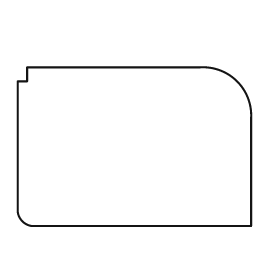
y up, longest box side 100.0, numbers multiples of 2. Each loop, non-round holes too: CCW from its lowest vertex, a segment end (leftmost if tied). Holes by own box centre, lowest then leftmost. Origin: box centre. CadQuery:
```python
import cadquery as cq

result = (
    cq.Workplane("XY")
    .moveTo(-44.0, -34.0)
    .lineTo(50.0, -34.0)
    .lineTo(50.0, 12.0)
    .threePointArc((44.0, 28.0), (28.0, 34.0))
    .lineTo(-46.0, 34.0)
    .lineTo(-46.0, 28.0)
    .lineTo(-50.0, 28.0)
    .lineTo(-50.0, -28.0)
    .threePointArc((-48.0, -32.0), (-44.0, -34.0))
    .close()
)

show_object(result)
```